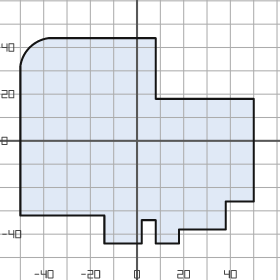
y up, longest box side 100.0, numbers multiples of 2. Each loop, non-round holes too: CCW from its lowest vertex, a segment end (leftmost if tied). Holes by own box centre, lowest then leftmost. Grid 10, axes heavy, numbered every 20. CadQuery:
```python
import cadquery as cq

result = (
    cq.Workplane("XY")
    .moveTo(-14.0, -44.0)
    .lineTo(2.0, -44.0)
    .lineTo(2.0, -34.0)
    .lineTo(8.0, -34.0)
    .lineTo(8.0, -44.0)
    .lineTo(18.0, -44.0)
    .lineTo(18.0, -38.0)
    .lineTo(38.0, -38.0)
    .lineTo(38.0, -26.0)
    .lineTo(50.0, -26.0)
    .lineTo(50.0, 18.0)
    .lineTo(8.0, 18.0)
    .lineTo(8.0, 44.0)
    .lineTo(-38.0, 44.0)
    .threePointArc((-46.0, 40.0), (-50.0, 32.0))
    .lineTo(-50.0, -32.0)
    .lineTo(-14.0, -32.0)
    .close()
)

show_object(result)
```